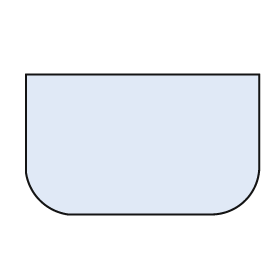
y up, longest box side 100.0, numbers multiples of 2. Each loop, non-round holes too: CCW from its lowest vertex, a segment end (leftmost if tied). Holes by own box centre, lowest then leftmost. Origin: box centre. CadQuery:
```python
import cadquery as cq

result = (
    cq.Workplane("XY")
    .moveTo(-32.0, -30.0)
    .lineTo(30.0, -30.0)
    .threePointArc((44.0, -24.0), (50.0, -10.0))
    .lineTo(50.0, 30.0)
    .lineTo(-50.0, 30.0)
    .lineTo(-50.0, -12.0)
    .threePointArc((-44.0, -24.0), (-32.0, -30.0))
    .close()
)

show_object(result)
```